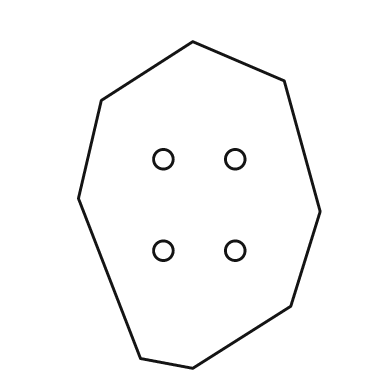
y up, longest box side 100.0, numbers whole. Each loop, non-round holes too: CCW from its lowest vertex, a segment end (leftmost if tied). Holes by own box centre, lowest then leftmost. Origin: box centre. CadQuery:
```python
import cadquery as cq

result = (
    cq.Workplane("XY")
    .moveTo(-2.0, -50.0)
    .lineTo(28.0, -31.0)
    .lineTo(37.0, -2.0)
    .lineTo(26.0, 38.0)
    .lineTo(-2.0, 50.0)
    .lineTo(-30.0, 32.0)
    .lineTo(-37.0, 2.0)
    .lineTo(-18.0, -47.0)
    .close()
    .moveTo(-11.0, -14.0)
    .circle(3.0)
    .moveTo(11.0, -14.0)
    .circle(3.0)
    .moveTo(-11.0, 14.0)
    .circle(3.0)
    .moveTo(11.0, 14.0)
    .circle(3.0)
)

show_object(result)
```